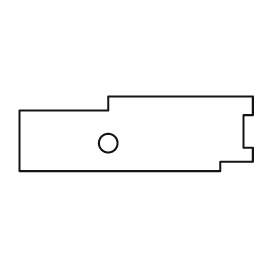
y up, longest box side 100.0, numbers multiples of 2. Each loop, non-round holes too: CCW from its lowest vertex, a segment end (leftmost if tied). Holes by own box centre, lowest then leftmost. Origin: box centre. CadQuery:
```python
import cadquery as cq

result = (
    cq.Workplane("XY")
    .moveTo(-50.0, -16.0)
    .lineTo(36.0, -16.0)
    .lineTo(36.0, -12.0)
    .lineTo(50.0, -12.0)
    .lineTo(50.0, -6.0)
    .lineTo(46.0, -6.0)
    .lineTo(46.0, 8.0)
    .lineTo(50.0, 8.0)
    .lineTo(50.0, 16.0)
    .lineTo(-12.0, 16.0)
    .lineTo(-12.0, 10.0)
    .lineTo(-50.0, 10.0)
    .close()
    .moveTo(-12.0, -4.0)
    .circle(4.0)
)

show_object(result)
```